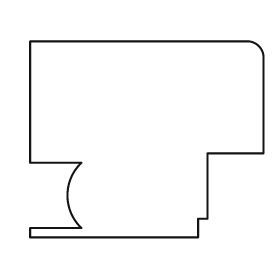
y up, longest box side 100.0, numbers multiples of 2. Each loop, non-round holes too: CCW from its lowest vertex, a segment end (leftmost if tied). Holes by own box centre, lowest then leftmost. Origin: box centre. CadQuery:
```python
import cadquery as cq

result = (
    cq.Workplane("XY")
    .moveTo(-50.0, -42.0)
    .lineTo(22.0, -42.0)
    .lineTo(22.0, -34.0)
    .lineTo(26.0, -34.0)
    .lineTo(26.0, -6.0)
    .lineTo(50.0, -6.0)
    .lineTo(50.0, 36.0)
    .threePointArc((48.0, 40.0), (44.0, 42.0))
    .lineTo(-50.0, 42.0)
    .lineTo(-50.0, -10.0)
    .lineTo(-28.0, -10.0)
    .threePointArc((-34.0, -24.0), (-28.0, -38.0))
    .lineTo(-50.0, -38.0)
    .close()
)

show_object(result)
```